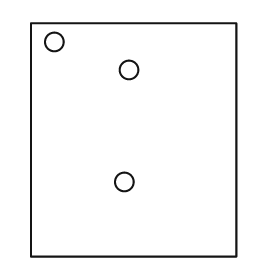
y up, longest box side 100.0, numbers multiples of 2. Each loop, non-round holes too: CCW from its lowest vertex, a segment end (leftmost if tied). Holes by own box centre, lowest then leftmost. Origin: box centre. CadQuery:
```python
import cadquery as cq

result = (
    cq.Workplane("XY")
    .moveTo(-44.0, -50.0)
    .lineTo(44.0, -50.0)
    .lineTo(44.0, 50.0)
    .lineTo(-44.0, 50.0)
    .close()
    .moveTo(-4.0, -18.0)
    .circle(4.0)
    .moveTo(-2.0, 30.0)
    .circle(4.0)
    .moveTo(-34.0, 42.0)
    .circle(4.0)
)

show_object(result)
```